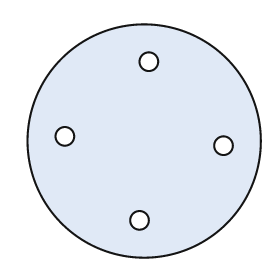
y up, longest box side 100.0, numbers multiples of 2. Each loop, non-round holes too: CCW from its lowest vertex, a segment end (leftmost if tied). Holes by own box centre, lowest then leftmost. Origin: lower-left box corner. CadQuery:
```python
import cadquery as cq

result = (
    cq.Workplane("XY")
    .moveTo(50.0, 50.0)
    .circle(50.0)
    .moveTo(48.0, 16.0)
    .circle(4.0)
    .moveTo(84.0, 48.0)
    .circle(4.0)
    .moveTo(16.0, 52.0)
    .circle(4.0)
    .moveTo(52.0, 84.0)
    .circle(4.0)
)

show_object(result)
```